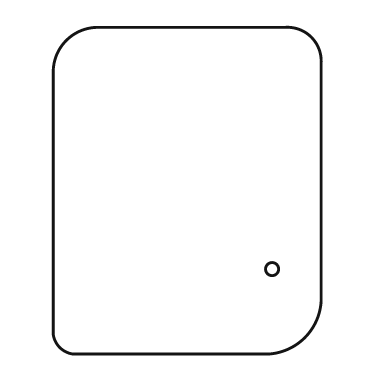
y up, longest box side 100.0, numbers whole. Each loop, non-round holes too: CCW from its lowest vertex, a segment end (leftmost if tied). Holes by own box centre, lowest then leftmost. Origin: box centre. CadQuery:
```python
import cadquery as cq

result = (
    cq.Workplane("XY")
    .moveTo(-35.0, -50.0)
    .lineTo(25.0, -50.0)
    .threePointArc((36.0, -45.0), (41.0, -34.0))
    .lineTo(41.0, 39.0)
    .threePointArc((38.0, 47.0), (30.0, 50.0))
    .lineTo(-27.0, 50.0)
    .threePointArc((-37.0, 46.0), (-41.0, 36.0))
    .lineTo(-41.0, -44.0)
    .threePointArc((-39.0, -48.0), (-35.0, -50.0))
    .close()
    .moveTo(26.0, -24.0)
    .circle(2.0)
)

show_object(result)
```